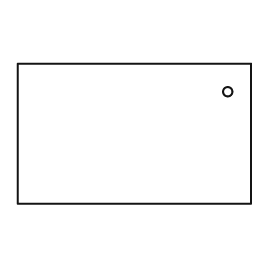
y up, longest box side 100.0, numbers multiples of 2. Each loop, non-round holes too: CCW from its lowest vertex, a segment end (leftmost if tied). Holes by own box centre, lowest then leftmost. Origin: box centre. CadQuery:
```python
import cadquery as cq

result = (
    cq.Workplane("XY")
    .moveTo(-50.0, -30.0)
    .lineTo(50.0, -30.0)
    .lineTo(50.0, 30.0)
    .lineTo(-50.0, 30.0)
    .close()
    .moveTo(40.0, 18.0)
    .circle(2.0)
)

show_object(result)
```